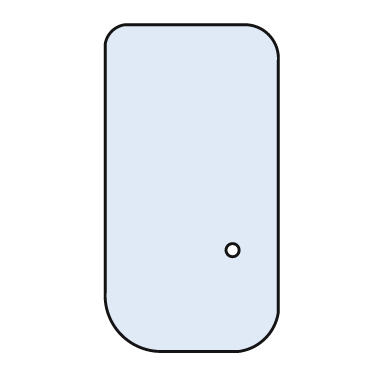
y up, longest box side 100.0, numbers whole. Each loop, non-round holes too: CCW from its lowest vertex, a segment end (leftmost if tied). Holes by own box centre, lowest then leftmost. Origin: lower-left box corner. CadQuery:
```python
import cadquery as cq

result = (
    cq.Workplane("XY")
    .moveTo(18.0, 0.0)
    .lineTo(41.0, 0.0)
    .threePointArc((49.0, 4.0), (53.0, 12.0))
    .lineTo(53.0, 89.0)
    .threePointArc((50.0, 97.0), (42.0, 100.0))
    .lineTo(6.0, 100.0)
    .threePointArc((2.0, 98.0), (0.0, 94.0))
    .lineTo(0.0, 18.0)
    .threePointArc((5.0, 5.0), (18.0, 0.0))
    .close()
    .moveTo(39.0, 31.0)
    .circle(2.0)
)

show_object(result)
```